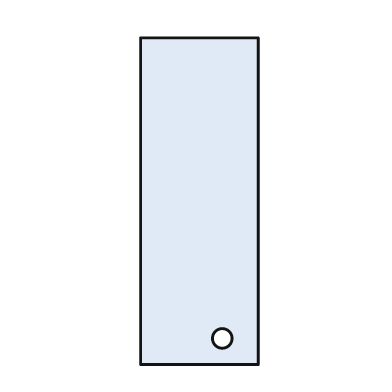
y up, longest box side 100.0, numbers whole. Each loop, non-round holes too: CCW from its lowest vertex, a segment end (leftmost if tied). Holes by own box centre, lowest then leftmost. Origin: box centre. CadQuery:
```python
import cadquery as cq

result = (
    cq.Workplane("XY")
    .moveTo(-18.0, -50.0)
    .lineTo(18.0, -50.0)
    .lineTo(18.0, 50.0)
    .lineTo(-18.0, 50.0)
    .close()
    .moveTo(7.0, -42.0)
    .circle(3.0)
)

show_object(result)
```